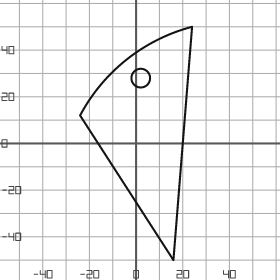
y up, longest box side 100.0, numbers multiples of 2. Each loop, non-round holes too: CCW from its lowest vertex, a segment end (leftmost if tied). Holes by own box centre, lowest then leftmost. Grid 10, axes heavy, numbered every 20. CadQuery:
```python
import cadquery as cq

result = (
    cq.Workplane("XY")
    .moveTo(16.0, -50.0)
    .lineTo(24.0, 50.0)
    .threePointArc((-4.0, 36.0), (-24.0, 12.0))
    .close()
    .moveTo(2.0, 28.0)
    .circle(4.0)
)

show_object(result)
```